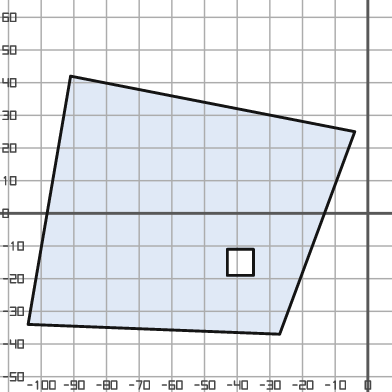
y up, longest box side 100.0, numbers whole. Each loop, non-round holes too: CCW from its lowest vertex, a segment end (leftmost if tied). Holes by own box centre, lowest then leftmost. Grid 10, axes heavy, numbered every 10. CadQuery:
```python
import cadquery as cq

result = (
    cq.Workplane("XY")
    .moveTo(-27.0, -37.0)
    .lineTo(-4.0, 25.0)
    .lineTo(-91.0, 42.0)
    .lineTo(-104.0, -34.0)
    .close()
    .moveTo(-43.0, -19.0)
    .lineTo(-35.0, -19.0)
    .lineTo(-35.0, -11.0)
    .lineTo(-43.0, -11.0)
    .close()
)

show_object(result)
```